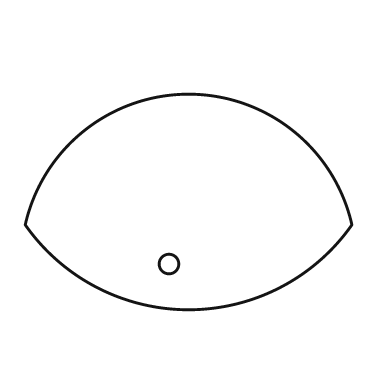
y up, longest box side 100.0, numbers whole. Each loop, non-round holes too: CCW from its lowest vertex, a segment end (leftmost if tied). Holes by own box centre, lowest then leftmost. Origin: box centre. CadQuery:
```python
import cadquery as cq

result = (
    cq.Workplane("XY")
    .moveTo(-50.0, -7.0)
    .threePointArc((0.0, -33.0), (50.0, -7.0))
    .threePointArc((0.0, 33.0), (-50.0, -7.0))
    .close()
    .moveTo(-6.0, -19.0)
    .circle(3.0)
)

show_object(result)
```